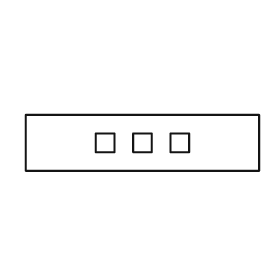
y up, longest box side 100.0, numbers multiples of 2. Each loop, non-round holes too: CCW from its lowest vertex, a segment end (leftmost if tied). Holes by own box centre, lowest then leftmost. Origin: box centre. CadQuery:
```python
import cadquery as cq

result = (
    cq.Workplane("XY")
    .moveTo(-50.0, -12.0)
    .lineTo(50.0, -12.0)
    .lineTo(50.0, 12.0)
    .lineTo(-50.0, 12.0)
    .close()
    .moveTo(-20.0, -4.0)
    .lineTo(-12.0, -4.0)
    .lineTo(-12.0, 4.0)
    .lineTo(-20.0, 4.0)
    .close()
    .moveTo(-4.0, -4.0)
    .lineTo(4.0, -4.0)
    .lineTo(4.0, 4.0)
    .lineTo(-4.0, 4.0)
    .close()
    .moveTo(12.0, -4.0)
    .lineTo(20.0, -4.0)
    .lineTo(20.0, 4.0)
    .lineTo(12.0, 4.0)
    .close()
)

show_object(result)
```